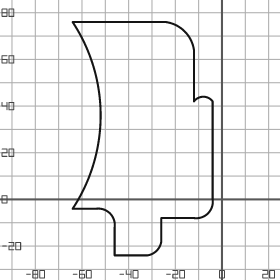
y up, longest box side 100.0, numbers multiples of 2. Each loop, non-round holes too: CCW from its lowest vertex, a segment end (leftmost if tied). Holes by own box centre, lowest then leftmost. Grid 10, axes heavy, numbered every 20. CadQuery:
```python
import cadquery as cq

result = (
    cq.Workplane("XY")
    .moveTo(-46.0, -24.0)
    .lineTo(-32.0, -24.0)
    .threePointArc((-28.0, -22.0), (-26.0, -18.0))
    .lineTo(-26.0, -8.0)
    .lineTo(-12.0, -8.0)
    .threePointArc((-6.0, -6.0), (-4.0, 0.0))
    .lineTo(-4.0, 42.0)
    .threePointArc((-8.0, 44.0), (-12.0, 42.0))
    .lineTo(-12.0, 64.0)
    .threePointArc((-16.0, 72.0), (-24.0, 76.0))
    .lineTo(-64.0, 76.0)
    .threePointArc((-52.0, 36.0), (-64.0, -4.0))
    .lineTo(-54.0, -4.0)
    .threePointArc((-48.0, -6.0), (-46.0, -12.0))
    .close()
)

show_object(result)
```